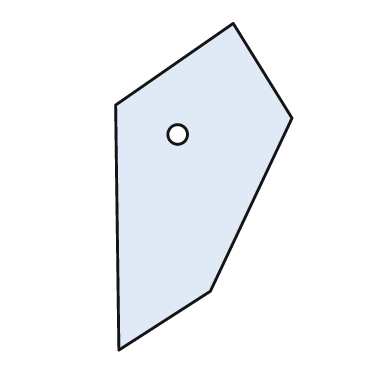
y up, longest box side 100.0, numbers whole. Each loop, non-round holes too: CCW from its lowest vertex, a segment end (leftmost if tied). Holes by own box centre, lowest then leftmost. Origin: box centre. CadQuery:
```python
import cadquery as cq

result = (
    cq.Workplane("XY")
    .moveTo(-26.0, -50.0)
    .lineTo(2.0, -32.0)
    .lineTo(27.0, 21.0)
    .lineTo(9.0, 50.0)
    .lineTo(-27.0, 25.0)
    .close()
    .moveTo(-8.0, 16.0)
    .circle(3.0)
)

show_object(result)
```